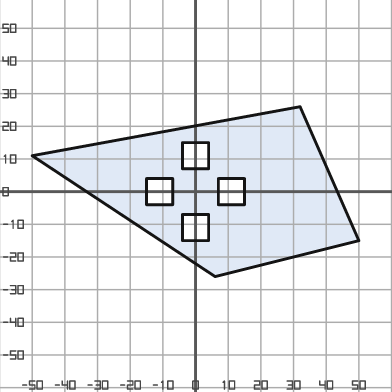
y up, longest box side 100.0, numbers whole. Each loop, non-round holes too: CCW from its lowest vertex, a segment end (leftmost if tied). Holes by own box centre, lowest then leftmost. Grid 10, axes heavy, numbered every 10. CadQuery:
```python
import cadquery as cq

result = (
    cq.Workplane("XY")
    .moveTo(6.0, -26.0)
    .lineTo(50.0, -15.0)
    .lineTo(32.0, 26.0)
    .lineTo(-50.0, 11.0)
    .close()
    .moveTo(-4.0, -15.0)
    .lineTo(4.0, -15.0)
    .lineTo(4.0, -7.0)
    .lineTo(-4.0, -7.0)
    .close()
    .moveTo(-15.0, -4.0)
    .lineTo(-7.0, -4.0)
    .lineTo(-7.0, 4.0)
    .lineTo(-15.0, 4.0)
    .close()
    .moveTo(7.0, -4.0)
    .lineTo(15.0, -4.0)
    .lineTo(15.0, 4.0)
    .lineTo(7.0, 4.0)
    .close()
    .moveTo(-4.0, 7.0)
    .lineTo(4.0, 7.0)
    .lineTo(4.0, 15.0)
    .lineTo(-4.0, 15.0)
    .close()
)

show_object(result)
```